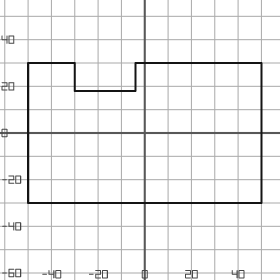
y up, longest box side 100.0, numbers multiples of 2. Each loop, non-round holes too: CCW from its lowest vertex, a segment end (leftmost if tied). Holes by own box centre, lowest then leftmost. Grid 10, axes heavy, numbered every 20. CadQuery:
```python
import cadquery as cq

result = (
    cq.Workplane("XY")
    .moveTo(-50.0, -30.0)
    .lineTo(50.0, -30.0)
    .lineTo(50.0, 30.0)
    .lineTo(-4.0, 30.0)
    .lineTo(-4.0, 18.0)
    .lineTo(-30.0, 18.0)
    .lineTo(-30.0, 30.0)
    .lineTo(-50.0, 30.0)
    .close()
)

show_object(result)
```